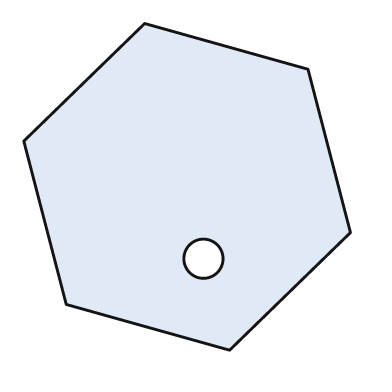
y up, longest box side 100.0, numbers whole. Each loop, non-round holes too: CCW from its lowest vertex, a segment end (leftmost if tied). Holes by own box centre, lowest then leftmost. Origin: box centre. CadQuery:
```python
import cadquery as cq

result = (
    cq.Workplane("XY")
    .moveTo(13.0, -50.0)
    .lineTo(50.0, -14.0)
    .lineTo(37.0, 36.0)
    .lineTo(-13.0, 50.0)
    .lineTo(-50.0, 14.0)
    .lineTo(-37.0, -36.0)
    .close()
    .moveTo(5.0, -22.0)
    .circle(6.0)
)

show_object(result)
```